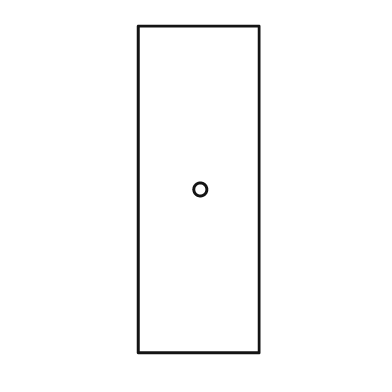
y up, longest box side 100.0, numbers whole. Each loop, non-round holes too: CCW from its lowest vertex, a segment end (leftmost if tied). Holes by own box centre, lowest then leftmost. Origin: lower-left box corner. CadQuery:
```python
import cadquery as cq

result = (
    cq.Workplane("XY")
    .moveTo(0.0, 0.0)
    .lineTo(37.0, 0.0)
    .lineTo(37.0, 100.0)
    .lineTo(0.0, 100.0)
    .close()
    .moveTo(19.0, 50.0)
    .circle(2.0)
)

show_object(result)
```